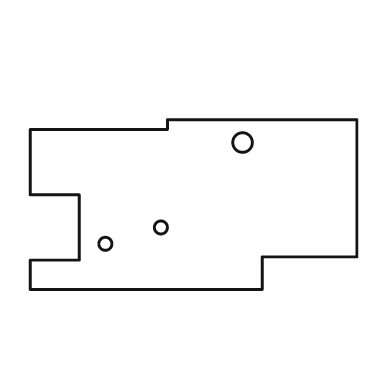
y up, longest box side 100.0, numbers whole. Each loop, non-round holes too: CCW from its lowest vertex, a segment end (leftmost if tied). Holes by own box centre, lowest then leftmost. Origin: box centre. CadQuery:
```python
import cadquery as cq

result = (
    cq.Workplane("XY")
    .moveTo(-50.0, -26.0)
    .lineTo(21.0, -26.0)
    .lineTo(21.0, -16.0)
    .lineTo(50.0, -16.0)
    .lineTo(50.0, 26.0)
    .lineTo(-8.0, 26.0)
    .lineTo(-8.0, 23.0)
    .lineTo(-50.0, 23.0)
    .lineTo(-50.0, 3.0)
    .lineTo(-35.0, 3.0)
    .lineTo(-35.0, -17.0)
    .lineTo(-50.0, -17.0)
    .close()
    .moveTo(-27.0, -12.0)
    .circle(2.0)
    .moveTo(-10.0, -7.0)
    .circle(2.0)
    .moveTo(15.0, 19.0)
    .circle(3.0)
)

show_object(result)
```